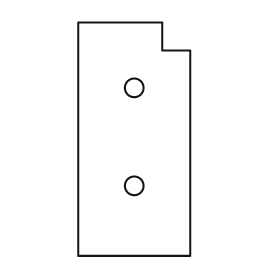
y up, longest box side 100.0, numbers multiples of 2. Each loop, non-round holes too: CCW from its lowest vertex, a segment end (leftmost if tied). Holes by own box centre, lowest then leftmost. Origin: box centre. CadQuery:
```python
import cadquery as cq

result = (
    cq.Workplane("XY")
    .moveTo(-24.0, -50.0)
    .lineTo(24.0, -50.0)
    .lineTo(24.0, 38.0)
    .lineTo(12.0, 38.0)
    .lineTo(12.0, 50.0)
    .lineTo(-24.0, 50.0)
    .close()
    .moveTo(0.0, -20.0)
    .circle(4.0)
    .moveTo(0.0, 22.0)
    .circle(4.0)
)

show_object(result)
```